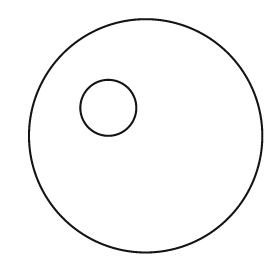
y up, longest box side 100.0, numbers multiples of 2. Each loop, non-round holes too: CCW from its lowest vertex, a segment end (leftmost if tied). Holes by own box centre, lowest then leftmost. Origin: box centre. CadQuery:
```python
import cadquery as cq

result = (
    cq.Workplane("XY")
    .moveTo(0.0, 0.0)
    .circle(50.0)
    .moveTo(-16.0, 12.0)
    .circle(12.0)
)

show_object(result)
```